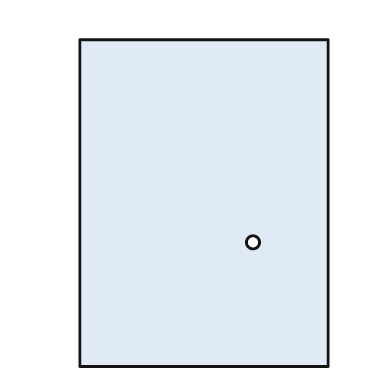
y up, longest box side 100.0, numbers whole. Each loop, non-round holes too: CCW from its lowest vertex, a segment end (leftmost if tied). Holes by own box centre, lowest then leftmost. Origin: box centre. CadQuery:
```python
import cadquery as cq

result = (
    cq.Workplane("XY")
    .moveTo(-38.0, -50.0)
    .lineTo(38.0, -50.0)
    .lineTo(38.0, 50.0)
    .lineTo(-38.0, 50.0)
    .close()
    .moveTo(15.0, -12.0)
    .circle(2.0)
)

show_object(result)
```